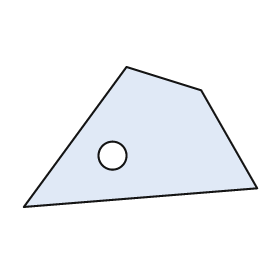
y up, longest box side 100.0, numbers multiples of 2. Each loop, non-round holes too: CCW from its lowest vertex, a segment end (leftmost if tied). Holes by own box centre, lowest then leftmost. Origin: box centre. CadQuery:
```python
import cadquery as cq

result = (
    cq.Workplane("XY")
    .moveTo(-50.0, -30.0)
    .lineTo(50.0, -22.0)
    .lineTo(26.0, 20.0)
    .lineTo(-6.0, 30.0)
    .close()
    .moveTo(-12.0, -8.0)
    .circle(6.0)
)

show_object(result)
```